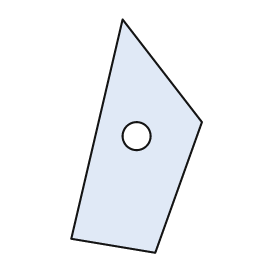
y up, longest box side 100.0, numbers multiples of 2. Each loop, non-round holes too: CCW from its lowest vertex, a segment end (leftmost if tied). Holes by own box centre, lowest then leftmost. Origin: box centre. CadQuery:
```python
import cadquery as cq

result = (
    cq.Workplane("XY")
    .moveTo(8.0, -50.0)
    .lineTo(28.0, 6.0)
    .lineTo(-6.0, 50.0)
    .lineTo(-28.0, -44.0)
    .close()
    .moveTo(0.0, 0.0)
    .circle(6.0)
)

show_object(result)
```